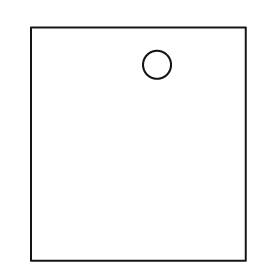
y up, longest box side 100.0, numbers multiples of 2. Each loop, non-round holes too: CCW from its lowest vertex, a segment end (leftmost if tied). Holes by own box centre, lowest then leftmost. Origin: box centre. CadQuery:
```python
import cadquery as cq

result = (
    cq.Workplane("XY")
    .moveTo(-46.0, -50.0)
    .lineTo(46.0, -50.0)
    .lineTo(46.0, 50.0)
    .lineTo(-46.0, 50.0)
    .close()
    .moveTo(8.0, 34.0)
    .circle(6.0)
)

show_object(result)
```